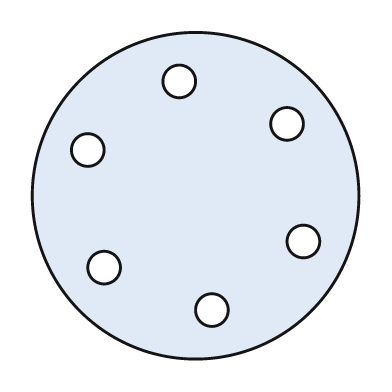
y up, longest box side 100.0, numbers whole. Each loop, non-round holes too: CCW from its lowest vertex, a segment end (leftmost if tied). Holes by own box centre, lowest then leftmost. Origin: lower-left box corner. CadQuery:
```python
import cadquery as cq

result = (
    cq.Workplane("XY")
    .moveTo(50.0, 50.0)
    .circle(50.0)
    .moveTo(55.0, 15.0)
    .circle(5.0)
    .moveTo(22.0, 28.0)
    .circle(5.0)
    .moveTo(83.0, 36.0)
    .circle(5.0)
    .moveTo(17.0, 64.0)
    .circle(5.0)
    .moveTo(78.0, 72.0)
    .circle(5.0)
    .moveTo(45.0, 85.0)
    .circle(5.0)
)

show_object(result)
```